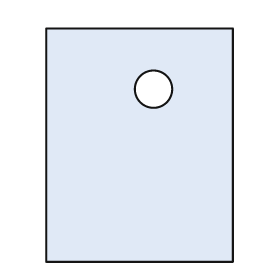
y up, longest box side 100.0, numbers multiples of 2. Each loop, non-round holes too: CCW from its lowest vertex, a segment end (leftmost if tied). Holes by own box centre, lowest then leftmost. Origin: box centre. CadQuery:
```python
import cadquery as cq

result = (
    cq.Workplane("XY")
    .moveTo(-40.0, -50.0)
    .lineTo(40.0, -50.0)
    .lineTo(40.0, 50.0)
    .lineTo(-40.0, 50.0)
    .close()
    .moveTo(6.0, 24.0)
    .circle(8.0)
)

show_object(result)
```